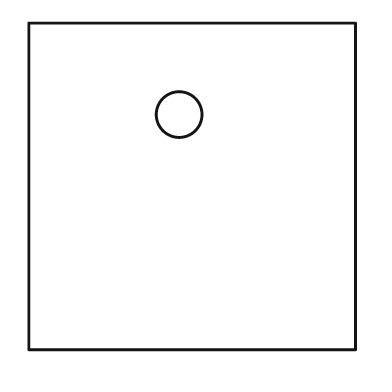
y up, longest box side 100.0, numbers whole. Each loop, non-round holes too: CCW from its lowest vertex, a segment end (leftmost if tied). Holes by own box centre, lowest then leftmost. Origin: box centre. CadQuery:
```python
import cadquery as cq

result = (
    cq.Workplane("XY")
    .moveTo(-50.0, -50.0)
    .lineTo(50.0, -50.0)
    .lineTo(50.0, 50.0)
    .lineTo(-50.0, 50.0)
    .close()
    .moveTo(-4.0, 22.0)
    .circle(7.0)
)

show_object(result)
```